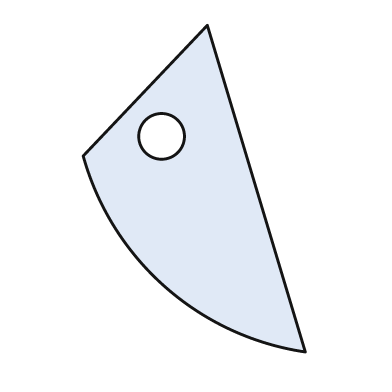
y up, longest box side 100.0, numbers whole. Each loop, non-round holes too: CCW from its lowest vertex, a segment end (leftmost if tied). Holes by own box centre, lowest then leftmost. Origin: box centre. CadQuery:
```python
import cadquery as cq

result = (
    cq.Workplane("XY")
    .moveTo(34.0, -50.0)
    .lineTo(4.0, 50.0)
    .lineTo(-34.0, 10.0)
    .threePointArc((-9.0, -30.0), (34.0, -50.0))
    .close()
    .moveTo(-10.0, 16.0)
    .circle(7.0)
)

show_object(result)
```